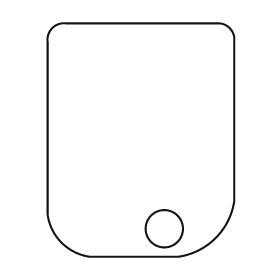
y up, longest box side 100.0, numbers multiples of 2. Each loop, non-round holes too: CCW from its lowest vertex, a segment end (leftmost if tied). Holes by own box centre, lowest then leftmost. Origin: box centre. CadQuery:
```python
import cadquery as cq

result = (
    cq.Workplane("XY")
    .moveTo(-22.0, -50.0)
    .lineTo(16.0, -50.0)
    .threePointArc((32.0, -42.0), (40.0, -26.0))
    .lineTo(40.0, 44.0)
    .threePointArc((38.0, 48.0), (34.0, 50.0))
    .lineTo(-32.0, 50.0)
    .threePointArc((-38.0, 48.0), (-40.0, 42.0))
    .lineTo(-40.0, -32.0)
    .threePointArc((-34.0, -44.0), (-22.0, -50.0))
    .close()
    .moveTo(10.0, -38.0)
    .circle(8.0)
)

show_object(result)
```